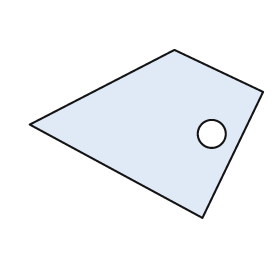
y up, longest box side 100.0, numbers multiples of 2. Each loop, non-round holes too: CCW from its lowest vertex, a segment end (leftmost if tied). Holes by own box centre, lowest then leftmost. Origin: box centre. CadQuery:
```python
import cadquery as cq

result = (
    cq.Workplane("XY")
    .moveTo(24.0, -36.0)
    .lineTo(50.0, 18.0)
    .lineTo(12.0, 36.0)
    .lineTo(-50.0, 4.0)
    .close()
    .moveTo(28.0, 0.0)
    .circle(6.0)
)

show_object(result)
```